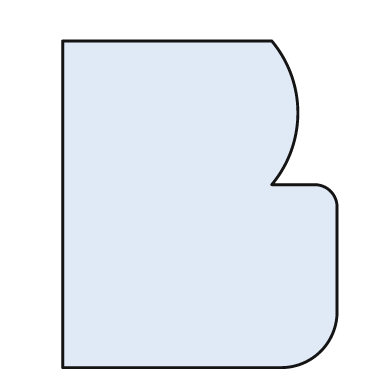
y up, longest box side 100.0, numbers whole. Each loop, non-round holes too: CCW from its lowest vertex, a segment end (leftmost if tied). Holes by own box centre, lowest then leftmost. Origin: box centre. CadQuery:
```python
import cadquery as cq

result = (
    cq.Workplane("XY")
    .moveTo(-42.0, -50.0)
    .lineTo(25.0, -50.0)
    .threePointArc((37.0, -45.0), (42.0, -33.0))
    .lineTo(42.0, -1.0)
    .threePointArc((40.0, 4.0), (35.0, 6.0))
    .lineTo(22.0, 6.0)
    .threePointArc((30.0, 28.0), (22.0, 50.0))
    .lineTo(-42.0, 50.0)
    .close()
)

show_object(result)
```